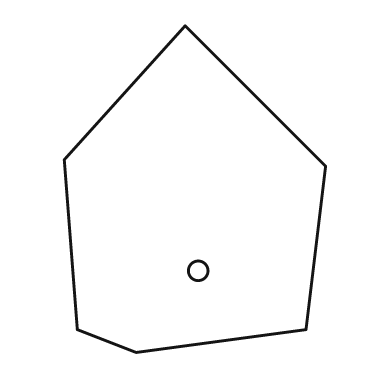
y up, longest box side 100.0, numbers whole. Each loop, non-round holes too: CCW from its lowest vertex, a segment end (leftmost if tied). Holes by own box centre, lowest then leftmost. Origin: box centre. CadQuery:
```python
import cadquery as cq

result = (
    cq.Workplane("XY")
    .moveTo(-18.0, -50.0)
    .lineTo(34.0, -43.0)
    .lineTo(40.0, 7.0)
    .lineTo(-3.0, 50.0)
    .lineTo(-40.0, 9.0)
    .lineTo(-36.0, -43.0)
    .close()
    .moveTo(1.0, -25.0)
    .circle(3.0)
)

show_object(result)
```